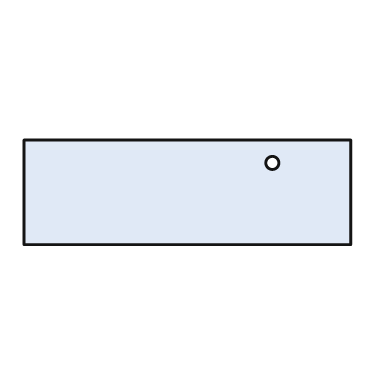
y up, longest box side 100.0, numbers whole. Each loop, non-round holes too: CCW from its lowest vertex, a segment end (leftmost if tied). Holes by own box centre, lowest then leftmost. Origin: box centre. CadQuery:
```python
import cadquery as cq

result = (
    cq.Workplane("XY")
    .moveTo(-50.0, -16.0)
    .lineTo(50.0, -16.0)
    .lineTo(50.0, 16.0)
    .lineTo(-50.0, 16.0)
    .close()
    .moveTo(26.0, 9.0)
    .circle(2.0)
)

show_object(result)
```